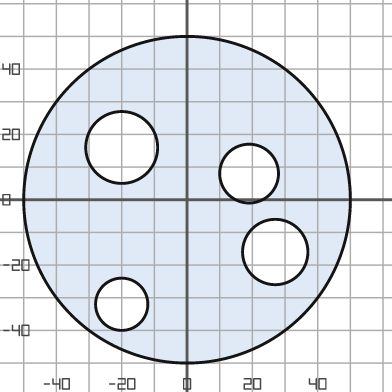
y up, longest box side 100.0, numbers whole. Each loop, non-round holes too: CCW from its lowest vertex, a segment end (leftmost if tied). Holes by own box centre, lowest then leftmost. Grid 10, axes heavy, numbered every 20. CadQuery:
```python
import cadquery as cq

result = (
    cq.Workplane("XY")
    .moveTo(0.0, 0.0)
    .circle(50.0)
    .moveTo(-20.0, -32.0)
    .circle(8.0)
    .moveTo(27.0, -16.0)
    .circle(10.0)
    .moveTo(19.0, 8.0)
    .circle(9.0)
    .moveTo(-20.0, 16.0)
    .circle(11.0)
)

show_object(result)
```